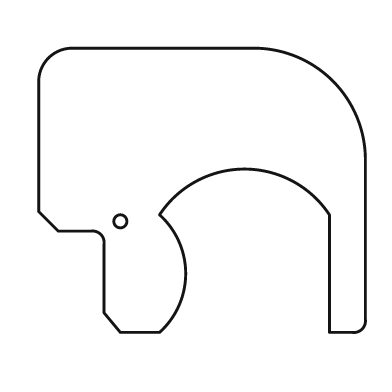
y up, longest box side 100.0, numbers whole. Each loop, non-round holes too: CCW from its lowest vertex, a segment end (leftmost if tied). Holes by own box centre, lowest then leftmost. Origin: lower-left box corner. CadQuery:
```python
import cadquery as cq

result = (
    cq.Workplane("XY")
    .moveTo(25.0, 0.0)
    .lineTo(37.0, 0.0)
    .threePointArc((45.0, 18.0), (37.0, 36.0))
    .threePointArc((63.0, 50.0), (89.0, 36.0))
    .lineTo(89.0, 0.0)
    .lineTo(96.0, 0.0)
    .threePointArc((99.0, 1.0), (100.0, 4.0))
    .lineTo(100.0, 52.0)
    .threePointArc((90.0, 77.0), (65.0, 87.0))
    .lineTo(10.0, 87.0)
    .threePointArc((3.0, 84.0), (0.0, 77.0))
    .lineTo(0.0, 37.0)
    .lineTo(6.0, 31.0)
    .lineTo(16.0, 31.0)
    .threePointArc((19.0, 30.0), (20.0, 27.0))
    .lineTo(20.0, 6.0)
    .close()
    .moveTo(25.0, 34.0)
    .circle(2.0)
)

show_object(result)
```